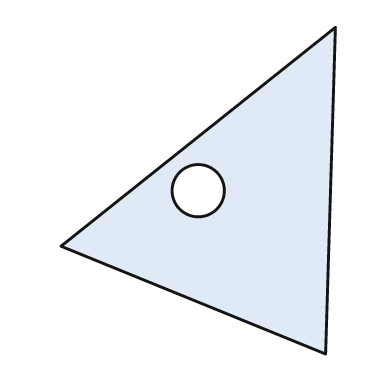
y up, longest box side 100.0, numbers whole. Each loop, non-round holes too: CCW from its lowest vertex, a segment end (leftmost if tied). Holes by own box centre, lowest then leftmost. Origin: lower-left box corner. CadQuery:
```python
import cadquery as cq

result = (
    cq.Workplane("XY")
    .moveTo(81.0, 0.0)
    .lineTo(84.0, 100.0)
    .lineTo(0.0, 33.0)
    .close()
    .moveTo(42.0, 50.0)
    .circle(8.0)
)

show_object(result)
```